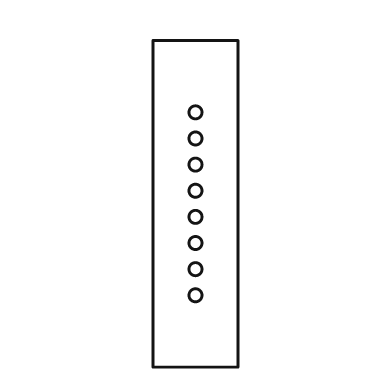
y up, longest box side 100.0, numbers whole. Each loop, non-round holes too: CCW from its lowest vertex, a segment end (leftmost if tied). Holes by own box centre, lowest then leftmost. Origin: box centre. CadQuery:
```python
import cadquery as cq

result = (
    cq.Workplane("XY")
    .moveTo(-13.0, -50.0)
    .lineTo(13.0, -50.0)
    .lineTo(13.0, 50.0)
    .lineTo(-13.0, 50.0)
    .close()
    .moveTo(0.0, -28.0)
    .circle(2.0)
    .moveTo(0.0, -20.0)
    .circle(2.0)
    .moveTo(0.0, -12.0)
    .circle(2.0)
    .moveTo(0.0, -4.0)
    .circle(2.0)
    .moveTo(0.0, 4.0)
    .circle(2.0)
    .moveTo(0.0, 12.0)
    .circle(2.0)
    .moveTo(0.0, 20.0)
    .circle(2.0)
    .moveTo(0.0, 28.0)
    .circle(2.0)
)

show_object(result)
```